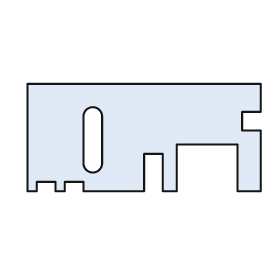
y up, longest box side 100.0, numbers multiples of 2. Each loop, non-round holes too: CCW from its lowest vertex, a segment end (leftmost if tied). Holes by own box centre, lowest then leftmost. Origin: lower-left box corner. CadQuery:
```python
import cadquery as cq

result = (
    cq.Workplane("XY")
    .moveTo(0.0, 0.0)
    .lineTo(4.0, 0.0)
    .lineTo(4.0, 4.0)
    .lineTo(12.0, 4.0)
    .lineTo(12.0, 0.0)
    .lineTo(16.0, 0.0)
    .lineTo(16.0, 4.0)
    .lineTo(24.0, 4.0)
    .lineTo(24.0, 0.0)
    .lineTo(50.0, 0.0)
    .lineTo(50.0, 16.0)
    .lineTo(58.0, 16.0)
    .lineTo(58.0, 0.0)
    .lineTo(64.0, 0.0)
    .lineTo(64.0, 20.0)
    .lineTo(90.0, 20.0)
    .lineTo(90.0, 0.0)
    .lineTo(100.0, 0.0)
    .lineTo(100.0, 26.0)
    .lineTo(92.0, 26.0)
    .lineTo(92.0, 34.0)
    .lineTo(100.0, 34.0)
    .lineTo(100.0, 46.0)
    .lineTo(0.0, 46.0)
    .close()
    .moveTo(24.0, 12.0)
    .threePointArc((28.0, 8.0), (32.0, 12.0))
    .lineTo(32.0, 32.0)
    .threePointArc((28.0, 36.0), (24.0, 32.0))
    .close()
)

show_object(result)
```